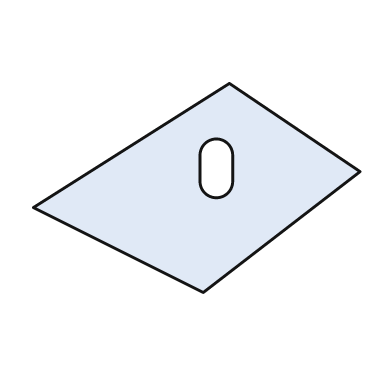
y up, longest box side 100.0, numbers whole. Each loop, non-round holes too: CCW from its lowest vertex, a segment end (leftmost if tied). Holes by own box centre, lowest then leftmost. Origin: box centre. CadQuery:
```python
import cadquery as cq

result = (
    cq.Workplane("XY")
    .moveTo(2.0, -32.0)
    .lineTo(50.0, 5.0)
    .lineTo(10.0, 32.0)
    .lineTo(-50.0, -6.0)
    .close()
    .moveTo(1.0, 2.0)
    .threePointArc((6.0, -3.0), (11.0, 2.0))
    .lineTo(11.0, 10.0)
    .threePointArc((6.0, 15.0), (1.0, 10.0))
    .close()
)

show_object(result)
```